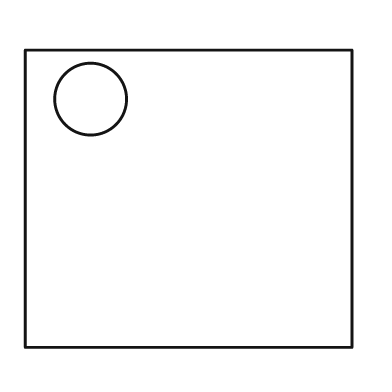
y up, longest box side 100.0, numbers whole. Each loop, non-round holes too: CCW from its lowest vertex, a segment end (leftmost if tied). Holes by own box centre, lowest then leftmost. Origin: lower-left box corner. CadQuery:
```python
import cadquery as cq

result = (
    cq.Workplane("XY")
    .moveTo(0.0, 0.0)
    .lineTo(100.0, 0.0)
    .lineTo(100.0, 91.0)
    .lineTo(0.0, 91.0)
    .close()
    .moveTo(20.0, 76.0)
    .circle(11.0)
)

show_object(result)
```